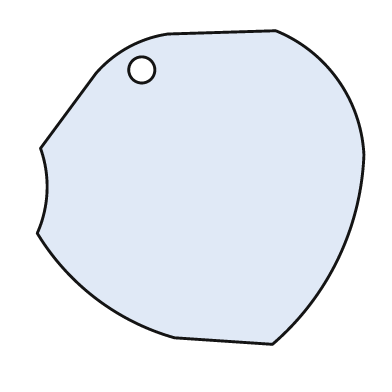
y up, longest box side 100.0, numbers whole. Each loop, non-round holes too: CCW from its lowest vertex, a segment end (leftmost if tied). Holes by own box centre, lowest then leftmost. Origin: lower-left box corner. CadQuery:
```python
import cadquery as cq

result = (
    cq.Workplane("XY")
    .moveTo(72.0, 0.0)
    .threePointArc((92.0, 26.0), (100.0, 58.0))
    .threePointArc((92.0, 81.0), (73.0, 96.0))
    .lineTo(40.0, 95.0)
    .threePointArc((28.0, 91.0), (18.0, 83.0))
    .lineTo(1.0, 60.0)
    .threePointArc((3.0, 47.0), (0.0, 34.0))
    .threePointArc((18.0, 14.0), (42.0, 2.0))
    .close()
    .moveTo(32.0, 84.0)
    .circle(4.0)
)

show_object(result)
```